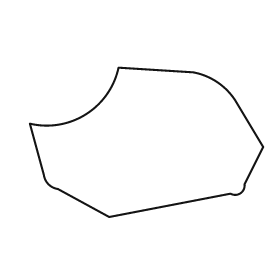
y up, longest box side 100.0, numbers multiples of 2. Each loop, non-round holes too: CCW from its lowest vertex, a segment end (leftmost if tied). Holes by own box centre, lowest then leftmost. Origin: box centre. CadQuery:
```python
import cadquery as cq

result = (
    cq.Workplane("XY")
    .moveTo(-16.0, -32.0)
    .lineTo(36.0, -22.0)
    .threePointArc((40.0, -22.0), (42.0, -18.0))
    .lineTo(50.0, -2.0)
    .lineTo(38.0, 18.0)
    .threePointArc((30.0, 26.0), (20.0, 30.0))
    .lineTo(-12.0, 32.0)
    .threePointArc((-26.0, 12.0), (-50.0, 8.0))
    .lineTo(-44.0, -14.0)
    .threePointArc((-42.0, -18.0), (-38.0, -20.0))
    .close()
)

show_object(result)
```